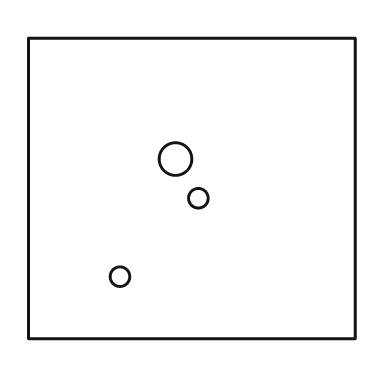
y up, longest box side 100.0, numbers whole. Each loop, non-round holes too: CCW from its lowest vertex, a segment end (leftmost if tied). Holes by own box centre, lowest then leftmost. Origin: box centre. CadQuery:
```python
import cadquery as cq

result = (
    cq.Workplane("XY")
    .moveTo(-50.0, -46.0)
    .lineTo(50.0, -46.0)
    .lineTo(50.0, 46.0)
    .lineTo(-50.0, 46.0)
    .close()
    .moveTo(-22.0, -27.0)
    .circle(3.0)
    .moveTo(2.0, -3.0)
    .circle(3.0)
    .moveTo(-5.0, 9.0)
    .circle(5.0)
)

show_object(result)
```